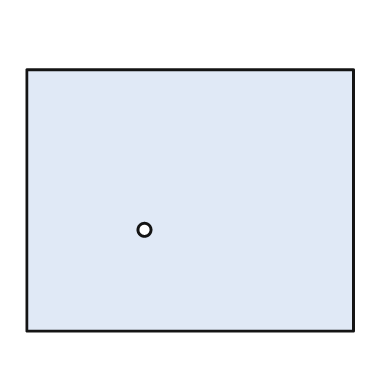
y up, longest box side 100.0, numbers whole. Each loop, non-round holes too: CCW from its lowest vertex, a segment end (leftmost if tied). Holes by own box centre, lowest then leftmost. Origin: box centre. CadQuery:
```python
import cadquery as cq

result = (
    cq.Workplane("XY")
    .moveTo(-50.0, -40.0)
    .lineTo(50.0, -40.0)
    .lineTo(50.0, 40.0)
    .lineTo(-50.0, 40.0)
    .close()
    .moveTo(-14.0, -9.0)
    .circle(2.0)
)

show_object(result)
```